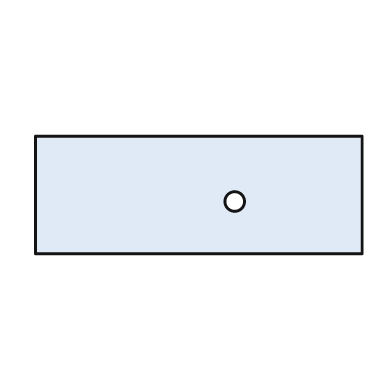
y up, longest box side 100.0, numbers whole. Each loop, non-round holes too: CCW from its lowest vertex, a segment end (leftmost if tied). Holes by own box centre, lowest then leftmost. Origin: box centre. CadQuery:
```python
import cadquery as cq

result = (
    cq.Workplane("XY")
    .moveTo(-50.0, -18.0)
    .lineTo(50.0, -18.0)
    .lineTo(50.0, 18.0)
    .lineTo(-50.0, 18.0)
    .close()
    .moveTo(11.0, -2.0)
    .circle(3.0)
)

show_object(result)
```